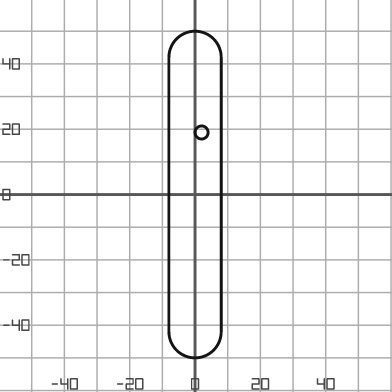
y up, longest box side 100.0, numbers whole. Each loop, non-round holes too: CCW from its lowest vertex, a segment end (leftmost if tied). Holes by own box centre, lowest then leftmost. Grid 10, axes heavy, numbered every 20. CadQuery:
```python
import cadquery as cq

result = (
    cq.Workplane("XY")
    .moveTo(-8.0, -42.0)
    .threePointArc((0.0, -50.0), (8.0, -42.0))
    .lineTo(8.0, 42.0)
    .threePointArc((0.0, 50.0), (-8.0, 42.0))
    .close()
    .moveTo(2.0, 19.0)
    .circle(2.0)
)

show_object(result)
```